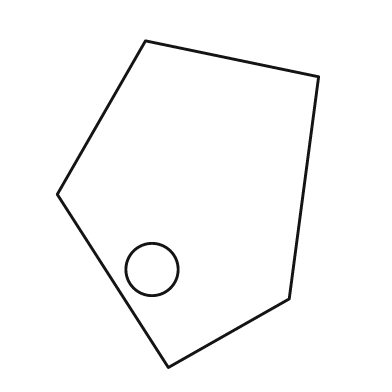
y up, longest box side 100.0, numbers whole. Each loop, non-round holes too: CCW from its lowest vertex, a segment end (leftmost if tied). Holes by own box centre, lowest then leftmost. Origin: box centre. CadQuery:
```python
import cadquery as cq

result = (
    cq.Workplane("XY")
    .moveTo(-6.0, -50.0)
    .lineTo(31.0, -29.0)
    .lineTo(40.0, 39.0)
    .lineTo(-13.0, 50.0)
    .lineTo(-40.0, 3.0)
    .close()
    .moveTo(-11.0, -20.0)
    .circle(8.0)
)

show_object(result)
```